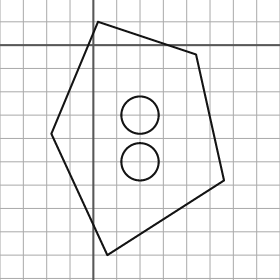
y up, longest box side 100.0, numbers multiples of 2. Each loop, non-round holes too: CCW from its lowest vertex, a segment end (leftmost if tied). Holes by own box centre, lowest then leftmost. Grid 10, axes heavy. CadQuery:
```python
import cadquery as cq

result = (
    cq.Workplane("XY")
    .moveTo(6.0, -90.0)
    .lineTo(56.0, -58.0)
    .lineTo(44.0, -4.0)
    .lineTo(2.0, 10.0)
    .lineTo(-18.0, -38.0)
    .close()
    .moveTo(20.0, -50.0)
    .circle(8.0)
    .moveTo(20.0, -30.0)
    .circle(8.0)
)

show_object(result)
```